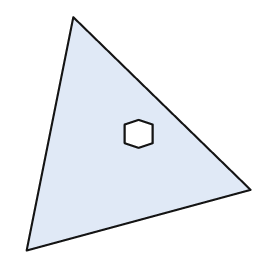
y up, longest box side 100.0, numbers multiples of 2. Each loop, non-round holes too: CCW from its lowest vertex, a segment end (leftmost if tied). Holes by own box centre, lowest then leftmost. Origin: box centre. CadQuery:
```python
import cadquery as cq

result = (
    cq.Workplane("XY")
    .moveTo(-48.0, -50.0)
    .lineTo(48.0, -24.0)
    .lineTo(-28.0, 50.0)
    .close()
    .moveTo(0.0, -6.0)
    .lineTo(6.0, -4.0)
    .lineTo(6.0, 4.0)
    .lineTo(0.0, 6.0)
    .lineTo(-6.0, 4.0)
    .lineTo(-6.0, -4.0)
    .close()
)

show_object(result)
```